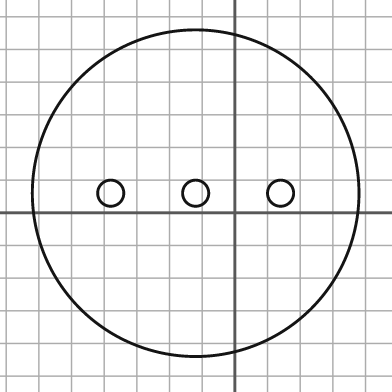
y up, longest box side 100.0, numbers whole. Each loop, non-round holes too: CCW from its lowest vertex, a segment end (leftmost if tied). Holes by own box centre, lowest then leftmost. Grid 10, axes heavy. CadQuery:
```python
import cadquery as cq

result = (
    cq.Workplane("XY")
    .moveTo(-12.0, 6.0)
    .circle(50.0)
    .moveTo(-38.0, 6.0)
    .circle(4.0)
    .moveTo(-12.0, 6.0)
    .circle(4.0)
    .moveTo(14.0, 6.0)
    .circle(4.0)
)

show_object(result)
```